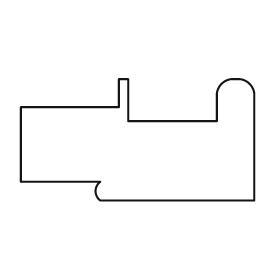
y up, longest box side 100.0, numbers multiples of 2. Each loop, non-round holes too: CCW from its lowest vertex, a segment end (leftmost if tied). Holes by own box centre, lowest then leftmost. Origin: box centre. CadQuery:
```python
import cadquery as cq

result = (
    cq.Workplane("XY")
    .moveTo(-16.0, -26.0)
    .lineTo(50.0, -26.0)
    .lineTo(50.0, 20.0)
    .threePointArc((48.0, 24.0), (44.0, 26.0))
    .lineTo(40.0, 26.0)
    .threePointArc((36.0, 24.0), (34.0, 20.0))
    .lineTo(34.0, 8.0)
    .lineTo(-4.0, 8.0)
    .lineTo(-4.0, 26.0)
    .lineTo(-8.0, 26.0)
    .lineTo(-8.0, 14.0)
    .lineTo(-50.0, 14.0)
    .lineTo(-50.0, -18.0)
    .lineTo(-16.0, -18.0)
    .threePointArc((-18.0, -22.0), (-16.0, -26.0))
    .close()
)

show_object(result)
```